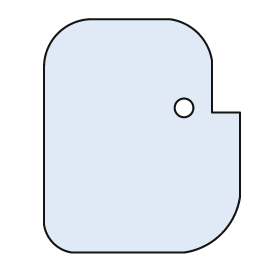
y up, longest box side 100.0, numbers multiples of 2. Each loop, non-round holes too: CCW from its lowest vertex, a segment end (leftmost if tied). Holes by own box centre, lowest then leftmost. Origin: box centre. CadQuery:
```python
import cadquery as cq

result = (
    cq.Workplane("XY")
    .moveTo(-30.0, -50.0)
    .lineTo(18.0, -50.0)
    .threePointArc((34.0, -42.0), (42.0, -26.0))
    .lineTo(42.0, 10.0)
    .lineTo(30.0, 10.0)
    .lineTo(30.0, 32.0)
    .threePointArc((24.0, 44.0), (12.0, 50.0))
    .lineTo(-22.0, 50.0)
    .threePointArc((-36.0, 44.0), (-42.0, 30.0))
    .lineTo(-42.0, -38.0)
    .threePointArc((-38.0, -46.0), (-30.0, -50.0))
    .close()
    .moveTo(18.0, 12.0)
    .circle(4.0)
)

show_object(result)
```